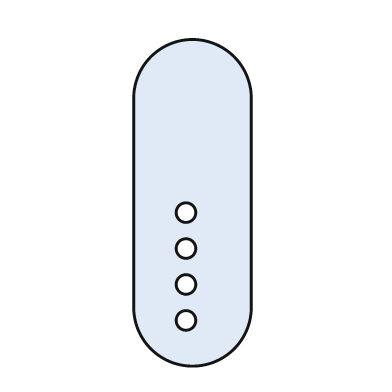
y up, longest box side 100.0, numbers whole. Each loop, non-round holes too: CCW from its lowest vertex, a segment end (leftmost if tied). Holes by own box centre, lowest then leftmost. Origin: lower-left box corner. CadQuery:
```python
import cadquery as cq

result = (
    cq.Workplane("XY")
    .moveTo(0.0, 18.0)
    .threePointArc((18.0, 0.0), (36.0, 18.0))
    .lineTo(36.0, 82.0)
    .threePointArc((18.0, 100.0), (0.0, 82.0))
    .close()
    .moveTo(16.0, 14.0)
    .circle(3.0)
    .moveTo(16.0, 25.0)
    .circle(3.0)
    .moveTo(16.0, 36.0)
    .circle(3.0)
    .moveTo(16.0, 47.0)
    .circle(3.0)
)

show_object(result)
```